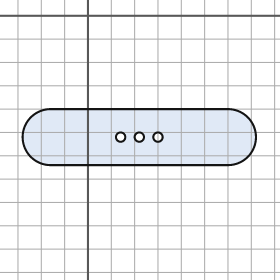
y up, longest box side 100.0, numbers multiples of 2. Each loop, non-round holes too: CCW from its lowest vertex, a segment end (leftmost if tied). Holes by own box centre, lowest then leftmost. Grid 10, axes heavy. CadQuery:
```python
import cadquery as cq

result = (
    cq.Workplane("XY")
    .moveTo(-16.0, -64.0)
    .lineTo(60.0, -64.0)
    .threePointArc((72.0, -52.0), (60.0, -40.0))
    .lineTo(-16.0, -40.0)
    .threePointArc((-28.0, -52.0), (-16.0, -64.0))
    .close()
    .moveTo(14.0, -52.0)
    .circle(2.0)
    .moveTo(22.0, -52.0)
    .circle(2.0)
    .moveTo(30.0, -52.0)
    .circle(2.0)
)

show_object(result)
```